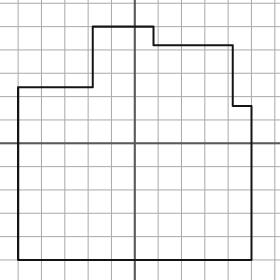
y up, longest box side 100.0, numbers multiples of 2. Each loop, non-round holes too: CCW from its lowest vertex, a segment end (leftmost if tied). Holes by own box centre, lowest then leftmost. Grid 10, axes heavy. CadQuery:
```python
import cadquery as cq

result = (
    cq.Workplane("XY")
    .moveTo(-50.0, -50.0)
    .lineTo(50.0, -50.0)
    .lineTo(50.0, 16.0)
    .lineTo(42.0, 16.0)
    .lineTo(42.0, 42.0)
    .lineTo(8.0, 42.0)
    .lineTo(8.0, 50.0)
    .lineTo(-18.0, 50.0)
    .lineTo(-18.0, 24.0)
    .lineTo(-50.0, 24.0)
    .close()
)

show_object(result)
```